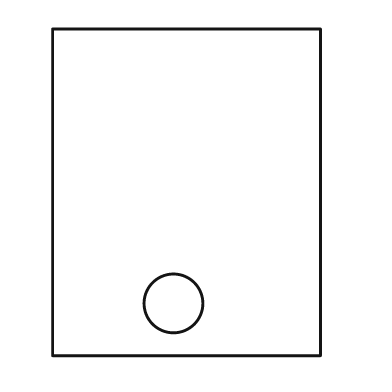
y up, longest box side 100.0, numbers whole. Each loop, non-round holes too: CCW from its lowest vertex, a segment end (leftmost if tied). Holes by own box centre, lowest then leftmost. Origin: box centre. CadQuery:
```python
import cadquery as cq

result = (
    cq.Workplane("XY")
    .moveTo(-41.0, -50.0)
    .lineTo(41.0, -50.0)
    .lineTo(41.0, 50.0)
    .lineTo(-41.0, 50.0)
    .close()
    .moveTo(-4.0, -34.0)
    .circle(9.0)
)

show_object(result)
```